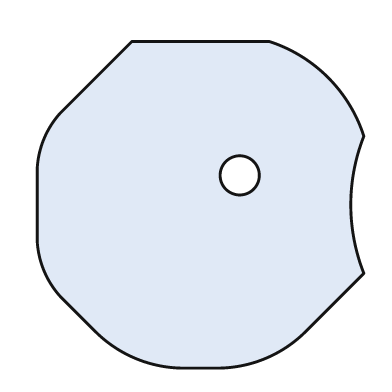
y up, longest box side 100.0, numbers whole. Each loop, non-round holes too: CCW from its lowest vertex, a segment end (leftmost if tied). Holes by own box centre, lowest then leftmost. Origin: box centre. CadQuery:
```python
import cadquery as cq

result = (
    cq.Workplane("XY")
    .moveTo(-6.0, -50.0)
    .lineTo(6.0, -50.0)
    .threePointArc((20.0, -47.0), (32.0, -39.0))
    .lineTo(50.0, -21.0)
    .threePointArc((46.0, 0.0), (50.0, 21.0))
    .threePointArc((39.0, 39.0), (21.0, 50.0))
    .lineTo(-21.0, 50.0)
    .lineTo(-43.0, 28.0)
    .threePointArc((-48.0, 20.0), (-50.0, 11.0))
    .lineTo(-50.0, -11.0)
    .threePointArc((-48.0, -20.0), (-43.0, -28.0))
    .lineTo(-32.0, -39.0)
    .threePointArc((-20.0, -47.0), (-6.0, -50.0))
    .close()
    .moveTo(12.0, 9.0)
    .circle(6.0)
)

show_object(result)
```